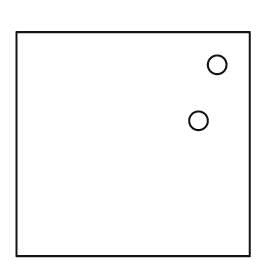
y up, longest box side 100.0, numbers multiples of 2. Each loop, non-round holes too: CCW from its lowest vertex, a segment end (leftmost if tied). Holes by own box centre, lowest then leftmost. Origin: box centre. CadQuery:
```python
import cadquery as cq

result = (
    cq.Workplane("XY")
    .moveTo(-50.0, -48.0)
    .lineTo(50.0, -48.0)
    .lineTo(50.0, 48.0)
    .lineTo(-50.0, 48.0)
    .close()
    .moveTo(28.0, 10.0)
    .circle(4.0)
    .moveTo(36.0, 34.0)
    .circle(4.0)
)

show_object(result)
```